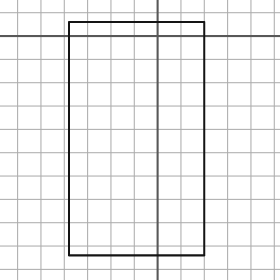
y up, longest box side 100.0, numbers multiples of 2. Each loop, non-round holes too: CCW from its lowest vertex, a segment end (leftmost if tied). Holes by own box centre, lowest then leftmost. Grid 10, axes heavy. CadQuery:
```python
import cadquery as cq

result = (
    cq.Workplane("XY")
    .moveTo(-38.0, -94.0)
    .lineTo(20.0, -94.0)
    .lineTo(20.0, 6.0)
    .lineTo(-38.0, 6.0)
    .close()
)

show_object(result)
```